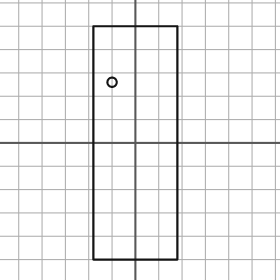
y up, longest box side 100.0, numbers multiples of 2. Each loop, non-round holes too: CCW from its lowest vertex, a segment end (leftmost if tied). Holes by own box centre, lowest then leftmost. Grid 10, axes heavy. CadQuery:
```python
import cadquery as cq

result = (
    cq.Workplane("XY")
    .moveTo(-18.0, -50.0)
    .lineTo(18.0, -50.0)
    .lineTo(18.0, 50.0)
    .lineTo(-18.0, 50.0)
    .close()
    .moveTo(-10.0, 26.0)
    .circle(2.0)
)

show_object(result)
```